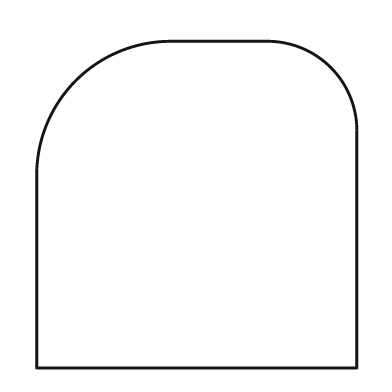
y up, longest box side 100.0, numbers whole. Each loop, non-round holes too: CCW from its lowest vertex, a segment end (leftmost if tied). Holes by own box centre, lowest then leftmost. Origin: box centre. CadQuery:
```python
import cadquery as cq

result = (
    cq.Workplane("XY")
    .moveTo(-49.0, -50.0)
    .lineTo(49.0, -50.0)
    .lineTo(49.0, 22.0)
    .threePointArc((41.0, 42.0), (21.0, 50.0))
    .lineTo(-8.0, 50.0)
    .threePointArc((-37.0, 38.0), (-49.0, 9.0))
    .close()
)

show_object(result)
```